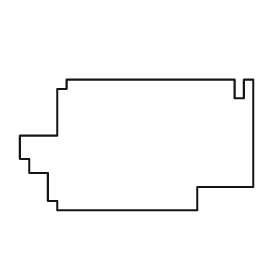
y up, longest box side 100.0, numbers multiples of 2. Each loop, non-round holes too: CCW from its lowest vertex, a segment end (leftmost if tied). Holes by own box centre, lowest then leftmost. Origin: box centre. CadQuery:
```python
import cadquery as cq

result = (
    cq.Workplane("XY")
    .moveTo(-34.0, -28.0)
    .lineTo(26.0, -28.0)
    .lineTo(26.0, -18.0)
    .lineTo(50.0, -18.0)
    .lineTo(50.0, 28.0)
    .lineTo(46.0, 28.0)
    .lineTo(46.0, 20.0)
    .lineTo(42.0, 20.0)
    .lineTo(42.0, 28.0)
    .lineTo(-30.0, 28.0)
    .lineTo(-30.0, 24.0)
    .lineTo(-34.0, 24.0)
    .lineTo(-34.0, 4.0)
    .lineTo(-50.0, 4.0)
    .lineTo(-50.0, -6.0)
    .lineTo(-46.0, -6.0)
    .lineTo(-46.0, -12.0)
    .lineTo(-38.0, -12.0)
    .lineTo(-38.0, -24.0)
    .lineTo(-34.0, -24.0)
    .close()
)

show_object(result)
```